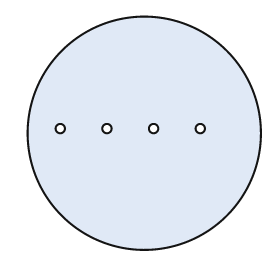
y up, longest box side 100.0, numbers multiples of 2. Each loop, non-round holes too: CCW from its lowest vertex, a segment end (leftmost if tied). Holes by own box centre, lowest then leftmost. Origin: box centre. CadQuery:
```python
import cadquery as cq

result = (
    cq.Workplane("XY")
    .moveTo(0.0, 0.0)
    .circle(50.0)
    .moveTo(-36.0, 2.0)
    .circle(2.0)
    .moveTo(-16.0, 2.0)
    .circle(2.0)
    .moveTo(4.0, 2.0)
    .circle(2.0)
    .moveTo(24.0, 2.0)
    .circle(2.0)
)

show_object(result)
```